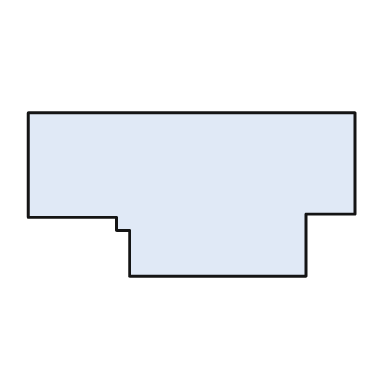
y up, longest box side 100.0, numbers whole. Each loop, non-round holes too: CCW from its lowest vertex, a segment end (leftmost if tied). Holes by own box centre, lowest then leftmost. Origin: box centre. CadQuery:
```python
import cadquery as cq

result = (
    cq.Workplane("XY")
    .moveTo(-19.0, -25.0)
    .lineTo(35.0, -25.0)
    .lineTo(35.0, -6.0)
    .lineTo(50.0, -6.0)
    .lineTo(50.0, 25.0)
    .lineTo(-50.0, 25.0)
    .lineTo(-50.0, -7.0)
    .lineTo(-23.0, -7.0)
    .lineTo(-23.0, -11.0)
    .lineTo(-19.0, -11.0)
    .close()
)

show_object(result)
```